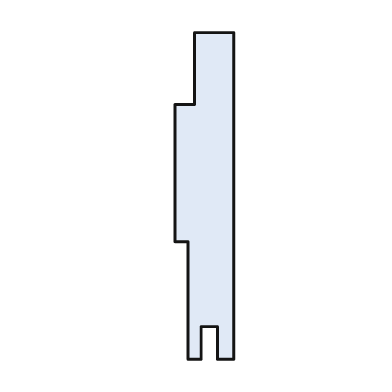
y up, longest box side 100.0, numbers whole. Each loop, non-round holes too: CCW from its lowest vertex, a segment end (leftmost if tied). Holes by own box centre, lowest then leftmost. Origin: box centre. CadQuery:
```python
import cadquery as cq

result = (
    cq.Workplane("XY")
    .moveTo(-5.0, -50.0)
    .lineTo(-1.0, -50.0)
    .lineTo(-1.0, -40.0)
    .lineTo(4.0, -40.0)
    .lineTo(4.0, -50.0)
    .lineTo(9.0, -50.0)
    .lineTo(9.0, 50.0)
    .lineTo(-3.0, 50.0)
    .lineTo(-3.0, 28.0)
    .lineTo(-9.0, 28.0)
    .lineTo(-9.0, -14.0)
    .lineTo(-5.0, -14.0)
    .close()
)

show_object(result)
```